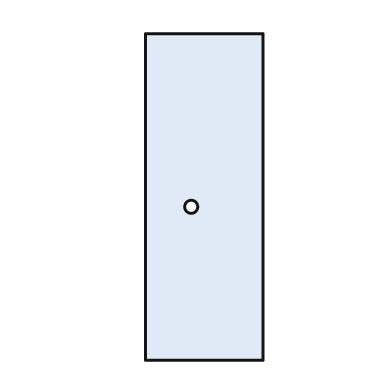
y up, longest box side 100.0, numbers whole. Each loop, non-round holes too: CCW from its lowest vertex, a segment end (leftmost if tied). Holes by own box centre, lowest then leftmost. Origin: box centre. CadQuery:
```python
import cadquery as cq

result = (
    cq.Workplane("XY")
    .moveTo(-18.0, -50.0)
    .lineTo(18.0, -50.0)
    .lineTo(18.0, 50.0)
    .lineTo(-18.0, 50.0)
    .close()
    .moveTo(-4.0, -3.0)
    .circle(2.0)
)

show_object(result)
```